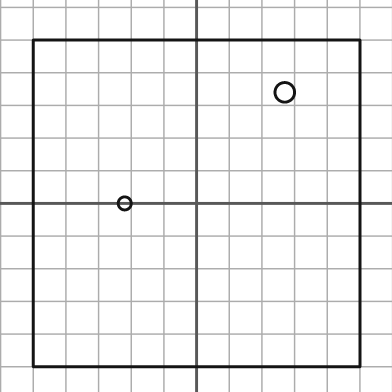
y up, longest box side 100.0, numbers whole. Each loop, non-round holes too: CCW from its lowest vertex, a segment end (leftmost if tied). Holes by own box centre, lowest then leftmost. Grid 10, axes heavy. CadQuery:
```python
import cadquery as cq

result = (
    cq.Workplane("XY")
    .moveTo(-50.0, -50.0)
    .lineTo(50.0, -50.0)
    .lineTo(50.0, 50.0)
    .lineTo(-50.0, 50.0)
    .close()
    .moveTo(-22.0, 0.0)
    .circle(2.0)
    .moveTo(27.0, 34.0)
    .circle(3.0)
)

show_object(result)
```